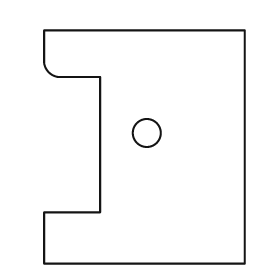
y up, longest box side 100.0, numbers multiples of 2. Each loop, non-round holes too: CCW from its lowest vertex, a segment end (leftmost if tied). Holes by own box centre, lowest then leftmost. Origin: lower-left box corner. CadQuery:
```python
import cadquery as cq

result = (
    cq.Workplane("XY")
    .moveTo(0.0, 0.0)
    .lineTo(86.0, 0.0)
    .lineTo(86.0, 100.0)
    .lineTo(0.0, 100.0)
    .lineTo(0.0, 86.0)
    .threePointArc((2.0, 82.0), (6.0, 80.0))
    .lineTo(24.0, 80.0)
    .lineTo(24.0, 22.0)
    .lineTo(0.0, 22.0)
    .close()
    .moveTo(44.0, 56.0)
    .circle(6.0)
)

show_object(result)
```